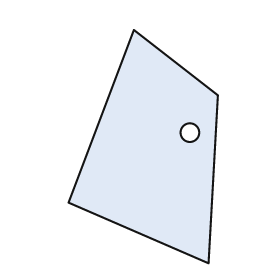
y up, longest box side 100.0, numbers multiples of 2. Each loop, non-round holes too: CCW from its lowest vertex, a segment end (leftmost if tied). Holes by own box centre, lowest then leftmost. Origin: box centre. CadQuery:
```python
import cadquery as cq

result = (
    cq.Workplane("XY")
    .moveTo(28.0, -50.0)
    .lineTo(32.0, 22.0)
    .lineTo(-4.0, 50.0)
    .lineTo(-32.0, -24.0)
    .close()
    .moveTo(20.0, 6.0)
    .circle(4.0)
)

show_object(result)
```